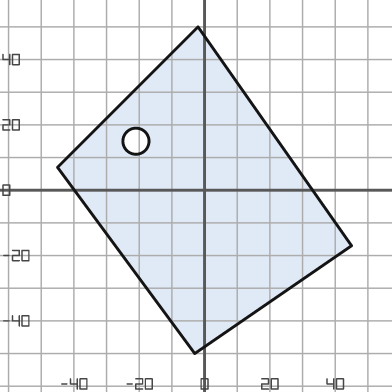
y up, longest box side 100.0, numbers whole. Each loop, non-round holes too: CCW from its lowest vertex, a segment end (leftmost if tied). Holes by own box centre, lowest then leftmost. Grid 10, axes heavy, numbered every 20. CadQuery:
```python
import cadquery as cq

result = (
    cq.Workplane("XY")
    .moveTo(-3.0, -50.0)
    .lineTo(45.0, -17.0)
    .lineTo(-2.0, 50.0)
    .lineTo(-45.0, 7.0)
    .close()
    .moveTo(-21.0, 15.0)
    .circle(4.0)
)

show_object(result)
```